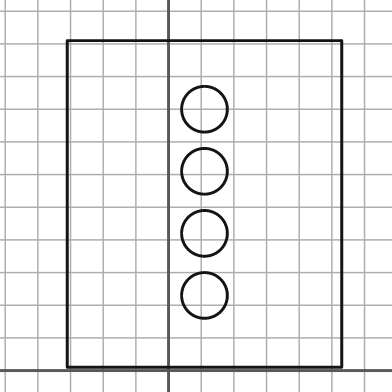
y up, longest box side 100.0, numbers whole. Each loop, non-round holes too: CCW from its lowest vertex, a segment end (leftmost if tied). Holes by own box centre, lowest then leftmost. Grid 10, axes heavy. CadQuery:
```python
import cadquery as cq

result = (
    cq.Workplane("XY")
    .moveTo(-31.0, 1.0)
    .lineTo(53.0, 1.0)
    .lineTo(53.0, 101.0)
    .lineTo(-31.0, 101.0)
    .close()
    .moveTo(11.0, 23.0)
    .circle(7.0)
    .moveTo(11.0, 42.0)
    .circle(7.0)
    .moveTo(11.0, 61.0)
    .circle(7.0)
    .moveTo(11.0, 80.0)
    .circle(7.0)
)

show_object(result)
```